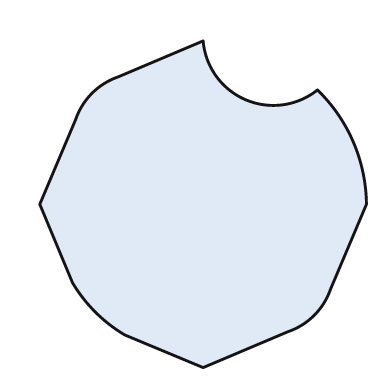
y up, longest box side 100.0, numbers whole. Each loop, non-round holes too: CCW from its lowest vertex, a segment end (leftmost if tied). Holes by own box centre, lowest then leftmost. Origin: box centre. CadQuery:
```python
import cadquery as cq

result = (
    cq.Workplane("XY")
    .moveTo(0.0, -50.0)
    .lineTo(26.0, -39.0)
    .threePointArc((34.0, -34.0), (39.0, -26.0))
    .lineTo(50.0, 0.0)
    .threePointArc((46.0, 19.0), (35.0, 35.0))
    .threePointArc((13.0, 32.0), (0.0, 50.0))
    .lineTo(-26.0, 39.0)
    .threePointArc((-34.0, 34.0), (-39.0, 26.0))
    .lineTo(-50.0, 0.0)
    .lineTo(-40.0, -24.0)
    .threePointArc((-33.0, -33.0), (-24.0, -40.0))
    .close()
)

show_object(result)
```